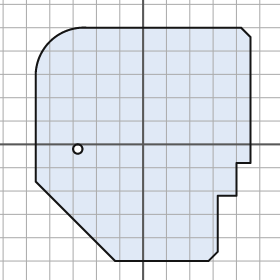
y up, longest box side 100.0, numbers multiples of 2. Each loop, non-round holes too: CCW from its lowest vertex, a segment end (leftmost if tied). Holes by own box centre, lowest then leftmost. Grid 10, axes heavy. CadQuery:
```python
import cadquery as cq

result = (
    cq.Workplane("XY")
    .moveTo(-12.0, -50.0)
    .lineTo(28.0, -50.0)
    .lineTo(32.0, -46.0)
    .lineTo(32.0, -22.0)
    .lineTo(40.0, -22.0)
    .lineTo(40.0, -8.0)
    .lineTo(46.0, -8.0)
    .lineTo(46.0, 46.0)
    .lineTo(42.0, 50.0)
    .lineTo(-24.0, 50.0)
    .threePointArc((-40.0, 44.0), (-46.0, 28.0))
    .lineTo(-46.0, -16.0)
    .close()
    .moveTo(-28.0, -2.0)
    .circle(2.0)
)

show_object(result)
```